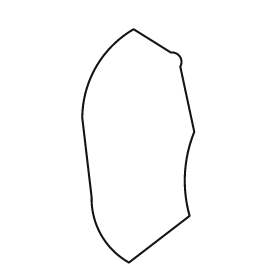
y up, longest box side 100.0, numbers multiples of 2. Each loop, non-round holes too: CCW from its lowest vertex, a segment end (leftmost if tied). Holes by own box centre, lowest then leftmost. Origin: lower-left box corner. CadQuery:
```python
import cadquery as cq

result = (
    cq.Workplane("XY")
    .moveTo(20.0, 0.0)
    .lineTo(46.0, 20.0)
    .threePointArc((44.0, 38.0), (48.0, 56.0))
    .lineTo(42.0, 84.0)
    .threePointArc((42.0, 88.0), (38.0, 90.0))
    .lineTo(22.0, 100.0)
    .threePointArc((6.0, 84.0), (0.0, 62.0))
    .lineTo(4.0, 28.0)
    .threePointArc((8.0, 12.0), (20.0, 0.0))
    .close()
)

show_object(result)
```